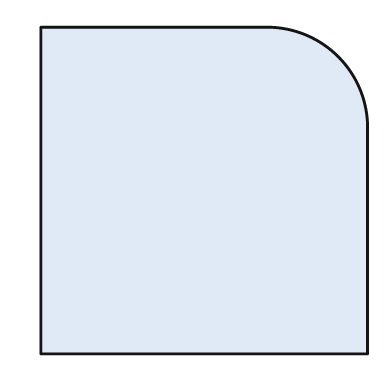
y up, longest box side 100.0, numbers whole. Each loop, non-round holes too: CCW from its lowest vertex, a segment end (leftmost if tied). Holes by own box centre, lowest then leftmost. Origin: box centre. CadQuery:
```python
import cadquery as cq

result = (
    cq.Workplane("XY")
    .moveTo(-50.0, -50.0)
    .lineTo(50.0, -50.0)
    .lineTo(50.0, 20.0)
    .threePointArc((41.0, 41.0), (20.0, 50.0))
    .lineTo(-50.0, 50.0)
    .close()
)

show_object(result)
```